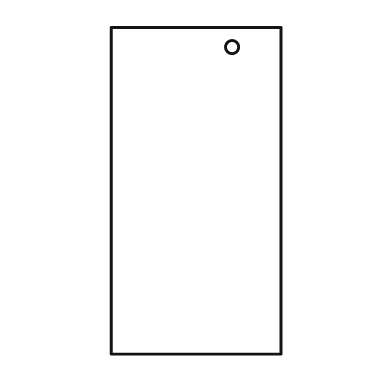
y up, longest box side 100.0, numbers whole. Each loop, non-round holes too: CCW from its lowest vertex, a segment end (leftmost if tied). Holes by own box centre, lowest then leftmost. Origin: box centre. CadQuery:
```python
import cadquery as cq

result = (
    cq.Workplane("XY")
    .moveTo(-26.0, -50.0)
    .lineTo(26.0, -50.0)
    .lineTo(26.0, 50.0)
    .lineTo(-26.0, 50.0)
    .close()
    .moveTo(11.0, 44.0)
    .circle(2.0)
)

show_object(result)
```